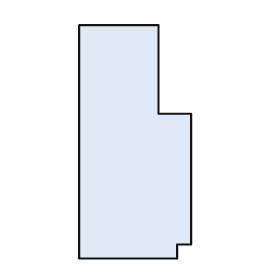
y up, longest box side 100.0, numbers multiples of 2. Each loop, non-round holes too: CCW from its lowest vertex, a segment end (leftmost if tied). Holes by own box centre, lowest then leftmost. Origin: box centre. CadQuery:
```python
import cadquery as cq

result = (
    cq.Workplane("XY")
    .moveTo(-24.0, -50.0)
    .lineTo(18.0, -50.0)
    .lineTo(18.0, -44.0)
    .lineTo(24.0, -44.0)
    .lineTo(24.0, 12.0)
    .lineTo(10.0, 12.0)
    .lineTo(10.0, 50.0)
    .lineTo(-24.0, 50.0)
    .close()
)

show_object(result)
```